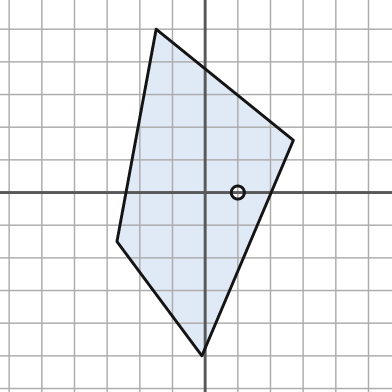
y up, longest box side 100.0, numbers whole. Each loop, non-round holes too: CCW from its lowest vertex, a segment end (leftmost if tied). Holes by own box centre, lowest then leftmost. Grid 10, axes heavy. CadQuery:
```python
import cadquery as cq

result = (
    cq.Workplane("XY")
    .moveTo(-1.0, -50.0)
    .lineTo(27.0, 16.0)
    .lineTo(-15.0, 50.0)
    .lineTo(-27.0, -15.0)
    .close()
    .moveTo(10.0, 0.0)
    .circle(2.0)
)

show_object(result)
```